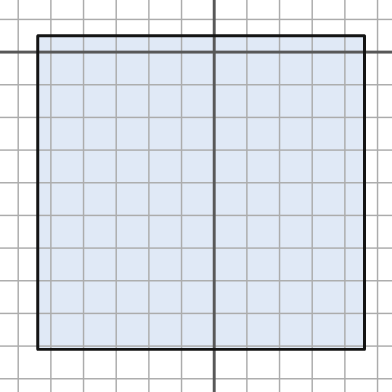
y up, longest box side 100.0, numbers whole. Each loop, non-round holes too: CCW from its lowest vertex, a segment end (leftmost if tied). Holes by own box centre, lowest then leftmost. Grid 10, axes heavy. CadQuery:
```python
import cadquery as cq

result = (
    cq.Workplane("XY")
    .moveTo(-54.0, -91.0)
    .lineTo(46.0, -91.0)
    .lineTo(46.0, 5.0)
    .lineTo(-54.0, 5.0)
    .close()
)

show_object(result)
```